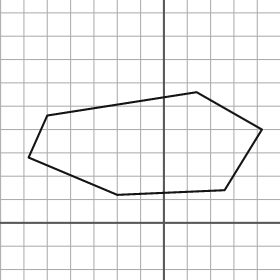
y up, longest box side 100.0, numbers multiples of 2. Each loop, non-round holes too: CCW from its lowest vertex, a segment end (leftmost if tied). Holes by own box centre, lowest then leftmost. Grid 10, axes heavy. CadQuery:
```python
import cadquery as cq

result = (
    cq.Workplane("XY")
    .moveTo(-20.0, 12.0)
    .lineTo(26.0, 14.0)
    .lineTo(42.0, 40.0)
    .lineTo(14.0, 56.0)
    .lineTo(-50.0, 46.0)
    .lineTo(-58.0, 28.0)
    .close()
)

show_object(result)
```